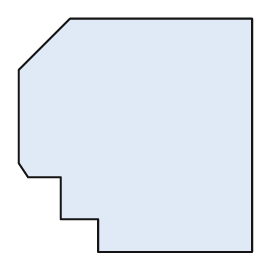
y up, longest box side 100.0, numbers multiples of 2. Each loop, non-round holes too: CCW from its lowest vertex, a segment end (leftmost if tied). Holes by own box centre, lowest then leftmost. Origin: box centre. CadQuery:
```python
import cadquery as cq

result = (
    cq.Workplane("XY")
    .moveTo(-16.0, -50.0)
    .lineTo(50.0, -50.0)
    .lineTo(50.0, 50.0)
    .lineTo(-28.0, 50.0)
    .lineTo(-50.0, 28.0)
    .lineTo(-50.0, -12.0)
    .lineTo(-46.0, -18.0)
    .lineTo(-32.0, -18.0)
    .lineTo(-32.0, -36.0)
    .lineTo(-16.0, -36.0)
    .close()
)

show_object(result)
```